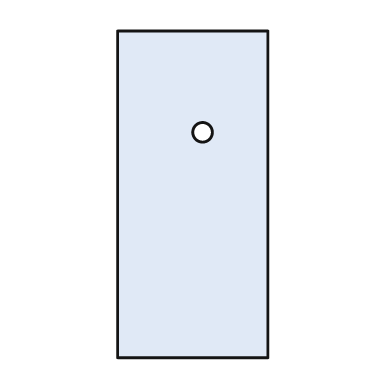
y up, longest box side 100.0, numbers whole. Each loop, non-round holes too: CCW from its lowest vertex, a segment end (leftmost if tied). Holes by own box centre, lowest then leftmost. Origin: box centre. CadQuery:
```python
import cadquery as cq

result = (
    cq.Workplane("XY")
    .moveTo(-23.0, -50.0)
    .lineTo(23.0, -50.0)
    .lineTo(23.0, 50.0)
    .lineTo(-23.0, 50.0)
    .close()
    .moveTo(3.0, 19.0)
    .circle(3.0)
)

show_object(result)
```